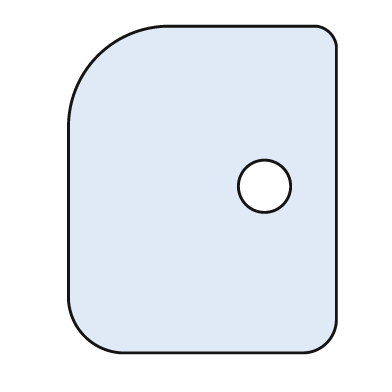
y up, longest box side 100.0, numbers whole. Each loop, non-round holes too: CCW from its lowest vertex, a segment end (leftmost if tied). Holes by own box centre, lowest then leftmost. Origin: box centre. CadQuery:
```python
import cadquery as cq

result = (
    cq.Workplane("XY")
    .moveTo(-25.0, -50.0)
    .lineTo(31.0, -50.0)
    .threePointArc((38.0, -47.0), (41.0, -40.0))
    .lineTo(41.0, 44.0)
    .threePointArc((39.0, 48.0), (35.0, 50.0))
    .lineTo(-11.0, 50.0)
    .threePointArc((-32.0, 41.0), (-41.0, 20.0))
    .lineTo(-41.0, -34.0)
    .threePointArc((-36.0, -45.0), (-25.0, -50.0))
    .close()
    .moveTo(19.0, 1.0)
    .circle(8.0)
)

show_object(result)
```